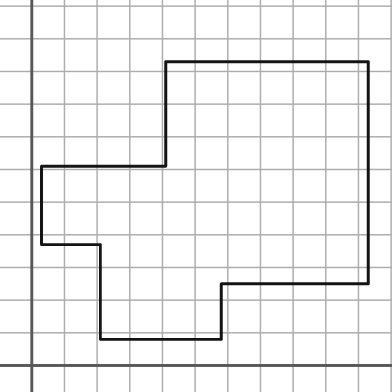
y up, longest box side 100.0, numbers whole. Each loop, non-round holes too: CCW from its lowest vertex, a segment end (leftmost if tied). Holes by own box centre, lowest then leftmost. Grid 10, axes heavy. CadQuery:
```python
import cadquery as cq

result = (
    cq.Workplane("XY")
    .moveTo(21.0, 8.0)
    .lineTo(58.0, 8.0)
    .lineTo(58.0, 25.0)
    .lineTo(103.0, 25.0)
    .lineTo(103.0, 93.0)
    .lineTo(41.0, 93.0)
    .lineTo(41.0, 61.0)
    .lineTo(3.0, 61.0)
    .lineTo(3.0, 37.0)
    .lineTo(21.0, 37.0)
    .close()
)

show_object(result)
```